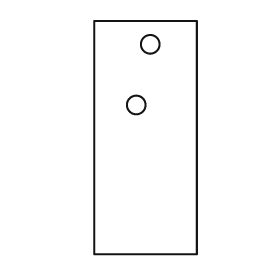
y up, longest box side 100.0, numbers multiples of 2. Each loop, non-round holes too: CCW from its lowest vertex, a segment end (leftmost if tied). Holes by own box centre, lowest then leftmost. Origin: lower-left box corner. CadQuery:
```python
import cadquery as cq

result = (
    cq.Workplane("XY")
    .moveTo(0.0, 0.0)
    .lineTo(44.0, 0.0)
    .lineTo(44.0, 100.0)
    .lineTo(0.0, 100.0)
    .close()
    .moveTo(18.0, 64.0)
    .circle(4.0)
    .moveTo(24.0, 90.0)
    .circle(4.0)
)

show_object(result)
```